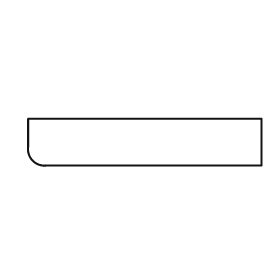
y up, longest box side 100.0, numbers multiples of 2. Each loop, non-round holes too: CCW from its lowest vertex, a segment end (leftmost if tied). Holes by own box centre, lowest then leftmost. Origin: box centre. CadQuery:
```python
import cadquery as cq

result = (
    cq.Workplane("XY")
    .moveTo(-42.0, -10.0)
    .lineTo(50.0, -10.0)
    .lineTo(50.0, 10.0)
    .lineTo(-50.0, 10.0)
    .lineTo(-50.0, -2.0)
    .threePointArc((-48.0, -8.0), (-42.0, -10.0))
    .close()
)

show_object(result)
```